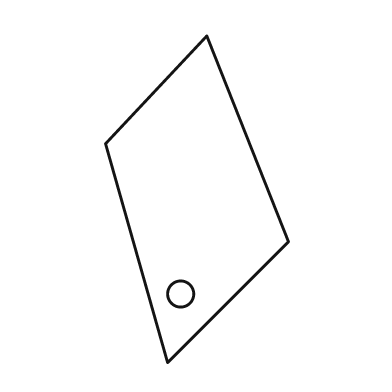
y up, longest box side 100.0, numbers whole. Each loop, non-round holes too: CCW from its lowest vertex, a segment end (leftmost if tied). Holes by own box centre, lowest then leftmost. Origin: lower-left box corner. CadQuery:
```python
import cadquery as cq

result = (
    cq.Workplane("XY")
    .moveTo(19.0, 0.0)
    .lineTo(56.0, 37.0)
    .lineTo(31.0, 100.0)
    .lineTo(0.0, 67.0)
    .close()
    .moveTo(23.0, 21.0)
    .circle(4.0)
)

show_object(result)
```